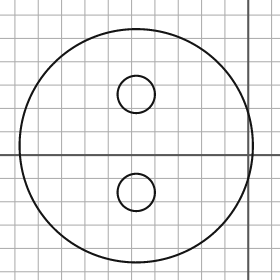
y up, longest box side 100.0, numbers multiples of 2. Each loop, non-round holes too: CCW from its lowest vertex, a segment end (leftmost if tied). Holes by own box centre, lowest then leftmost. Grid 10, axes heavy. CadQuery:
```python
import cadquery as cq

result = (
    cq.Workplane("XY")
    .moveTo(-48.0, 4.0)
    .circle(50.0)
    .moveTo(-48.0, -16.0)
    .circle(8.0)
    .moveTo(-48.0, 26.0)
    .circle(8.0)
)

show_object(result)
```